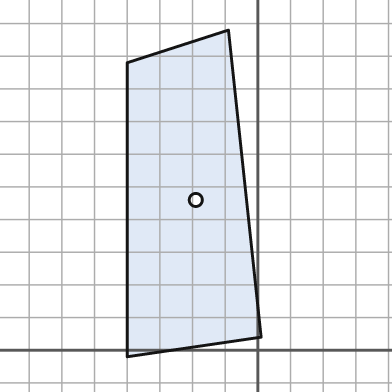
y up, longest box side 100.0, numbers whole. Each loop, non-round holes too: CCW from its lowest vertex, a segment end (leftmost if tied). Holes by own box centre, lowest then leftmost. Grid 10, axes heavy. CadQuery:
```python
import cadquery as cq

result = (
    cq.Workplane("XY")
    .moveTo(-40.0, -2.0)
    .lineTo(1.0, 4.0)
    .lineTo(-9.0, 98.0)
    .lineTo(-40.0, 88.0)
    .close()
    .moveTo(-19.0, 46.0)
    .circle(2.0)
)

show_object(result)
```